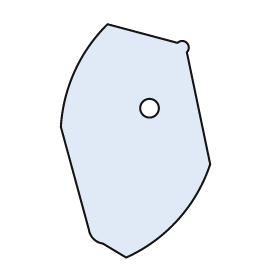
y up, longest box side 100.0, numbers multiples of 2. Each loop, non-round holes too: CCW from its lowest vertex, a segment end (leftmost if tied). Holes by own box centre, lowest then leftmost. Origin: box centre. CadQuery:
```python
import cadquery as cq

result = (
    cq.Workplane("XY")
    .moveTo(-4.0, -50.0)
    .threePointArc((18.0, -34.0), (32.0, -10.0))
    .lineTo(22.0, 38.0)
    .threePointArc((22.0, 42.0), (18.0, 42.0))
    .lineTo(-12.0, 50.0)
    .threePointArc((-26.0, 30.0), (-32.0, 6.0))
    .lineTo(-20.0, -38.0)
    .threePointArc((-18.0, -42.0), (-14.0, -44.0))
    .close()
    .moveTo(6.0, 14.0)
    .circle(4.0)
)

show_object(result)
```